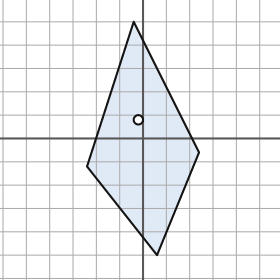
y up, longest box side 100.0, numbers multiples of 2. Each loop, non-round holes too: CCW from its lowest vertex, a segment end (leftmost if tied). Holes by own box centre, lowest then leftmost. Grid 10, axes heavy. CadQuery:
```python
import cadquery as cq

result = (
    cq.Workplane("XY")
    .moveTo(6.0, -50.0)
    .lineTo(24.0, -6.0)
    .lineTo(-4.0, 50.0)
    .lineTo(-24.0, -12.0)
    .close()
    .moveTo(-2.0, 8.0)
    .circle(2.0)
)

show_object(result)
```